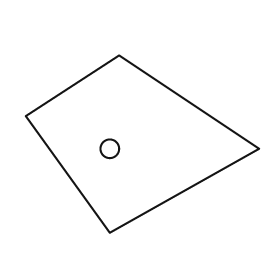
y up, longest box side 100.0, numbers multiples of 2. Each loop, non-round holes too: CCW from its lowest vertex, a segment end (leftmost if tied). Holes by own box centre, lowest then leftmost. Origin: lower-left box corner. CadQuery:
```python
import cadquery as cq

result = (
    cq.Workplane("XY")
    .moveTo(36.0, 0.0)
    .lineTo(100.0, 36.0)
    .lineTo(40.0, 76.0)
    .lineTo(0.0, 50.0)
    .close()
    .moveTo(36.0, 36.0)
    .circle(4.0)
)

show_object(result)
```